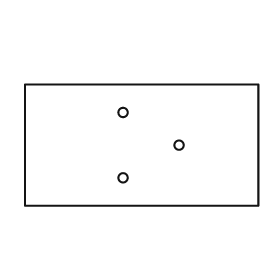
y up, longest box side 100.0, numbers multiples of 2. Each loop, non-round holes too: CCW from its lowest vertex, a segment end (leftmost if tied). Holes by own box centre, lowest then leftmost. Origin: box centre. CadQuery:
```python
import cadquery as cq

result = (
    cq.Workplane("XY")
    .moveTo(-50.0, -26.0)
    .lineTo(50.0, -26.0)
    .lineTo(50.0, 26.0)
    .lineTo(-50.0, 26.0)
    .close()
    .moveTo(-8.0, -14.0)
    .circle(2.0)
    .moveTo(16.0, 0.0)
    .circle(2.0)
    .moveTo(-8.0, 14.0)
    .circle(2.0)
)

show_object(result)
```